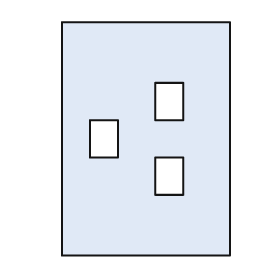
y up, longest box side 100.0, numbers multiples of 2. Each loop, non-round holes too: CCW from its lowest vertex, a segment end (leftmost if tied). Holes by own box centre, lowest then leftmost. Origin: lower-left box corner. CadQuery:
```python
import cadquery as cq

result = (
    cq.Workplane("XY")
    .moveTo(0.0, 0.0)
    .lineTo(72.0, 0.0)
    .lineTo(72.0, 100.0)
    .lineTo(0.0, 100.0)
    .close()
    .moveTo(40.0, 26.0)
    .lineTo(52.0, 26.0)
    .lineTo(52.0, 42.0)
    .lineTo(40.0, 42.0)
    .close()
    .moveTo(12.0, 42.0)
    .lineTo(24.0, 42.0)
    .lineTo(24.0, 58.0)
    .lineTo(12.0, 58.0)
    .close()
    .moveTo(40.0, 58.0)
    .lineTo(52.0, 58.0)
    .lineTo(52.0, 74.0)
    .lineTo(40.0, 74.0)
    .close()
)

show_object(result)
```